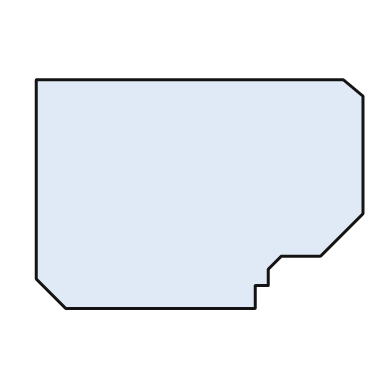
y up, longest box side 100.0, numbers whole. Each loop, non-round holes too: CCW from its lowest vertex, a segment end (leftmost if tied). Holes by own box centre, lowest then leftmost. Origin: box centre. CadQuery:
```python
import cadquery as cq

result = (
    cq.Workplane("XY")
    .moveTo(-41.0, -35.0)
    .lineTo(17.0, -35.0)
    .lineTo(17.0, -28.0)
    .lineTo(21.0, -28.0)
    .lineTo(21.0, -23.0)
    .lineTo(25.0, -19.0)
    .lineTo(37.0, -19.0)
    .lineTo(50.0, -6.0)
    .lineTo(50.0, 30.0)
    .lineTo(44.0, 35.0)
    .lineTo(-50.0, 35.0)
    .lineTo(-50.0, -26.0)
    .close()
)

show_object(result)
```